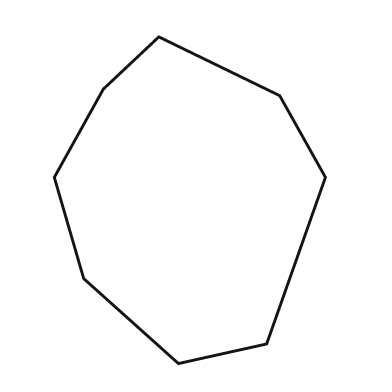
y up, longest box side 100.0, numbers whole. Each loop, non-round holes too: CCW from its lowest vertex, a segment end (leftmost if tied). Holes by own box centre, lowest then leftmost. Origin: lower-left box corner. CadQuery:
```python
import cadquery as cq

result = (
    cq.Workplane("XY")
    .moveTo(38.0, 0.0)
    .lineTo(65.0, 6.0)
    .lineTo(83.0, 57.0)
    .lineTo(69.0, 82.0)
    .lineTo(32.0, 100.0)
    .lineTo(15.0, 84.0)
    .lineTo(0.0, 57.0)
    .lineTo(9.0, 26.0)
    .close()
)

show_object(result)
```